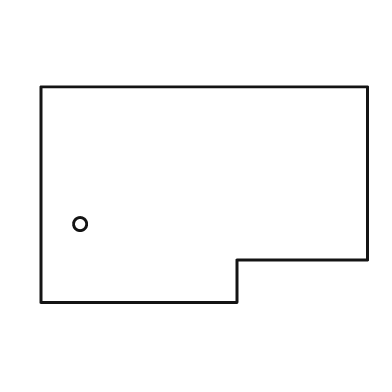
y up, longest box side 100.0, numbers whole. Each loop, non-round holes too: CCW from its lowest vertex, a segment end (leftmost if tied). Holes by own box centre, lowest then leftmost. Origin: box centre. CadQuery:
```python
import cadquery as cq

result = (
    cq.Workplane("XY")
    .moveTo(-50.0, -33.0)
    .lineTo(10.0, -33.0)
    .lineTo(10.0, -20.0)
    .lineTo(50.0, -20.0)
    .lineTo(50.0, 33.0)
    .lineTo(-50.0, 33.0)
    .close()
    .moveTo(-38.0, -9.0)
    .circle(2.0)
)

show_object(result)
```